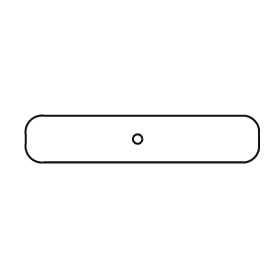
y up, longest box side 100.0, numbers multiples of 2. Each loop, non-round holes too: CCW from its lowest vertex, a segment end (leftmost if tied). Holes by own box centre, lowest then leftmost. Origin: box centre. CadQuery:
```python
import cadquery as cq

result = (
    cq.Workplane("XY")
    .moveTo(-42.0, -10.0)
    .lineTo(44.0, -10.0)
    .threePointArc((48.0, -8.0), (50.0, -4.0))
    .lineTo(50.0, 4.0)
    .threePointArc((48.0, 8.0), (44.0, 10.0))
    .lineTo(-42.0, 10.0)
    .threePointArc((-48.0, 8.0), (-50.0, 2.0))
    .lineTo(-50.0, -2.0)
    .threePointArc((-48.0, -8.0), (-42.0, -10.0))
    .close()
    .moveTo(-2.0, 0.0)
    .circle(2.0)
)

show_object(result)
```